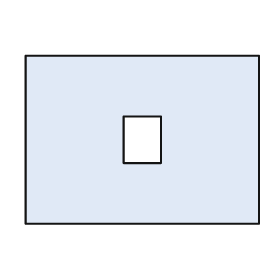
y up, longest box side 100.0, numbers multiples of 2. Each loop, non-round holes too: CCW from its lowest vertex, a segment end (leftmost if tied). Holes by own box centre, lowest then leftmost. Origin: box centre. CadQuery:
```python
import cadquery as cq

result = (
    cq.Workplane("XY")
    .moveTo(-50.0, -36.0)
    .lineTo(50.0, -36.0)
    .lineTo(50.0, 36.0)
    .lineTo(-50.0, 36.0)
    .close()
    .moveTo(-8.0, -10.0)
    .lineTo(8.0, -10.0)
    .lineTo(8.0, 10.0)
    .lineTo(-8.0, 10.0)
    .close()
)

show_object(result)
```